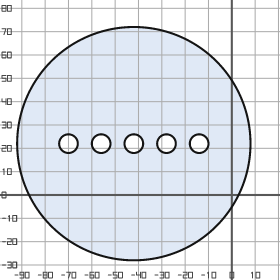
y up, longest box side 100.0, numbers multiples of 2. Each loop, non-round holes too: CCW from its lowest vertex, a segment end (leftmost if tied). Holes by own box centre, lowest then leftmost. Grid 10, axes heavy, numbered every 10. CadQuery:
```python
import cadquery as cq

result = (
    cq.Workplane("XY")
    .moveTo(-42.0, 22.0)
    .circle(50.0)
    .moveTo(-70.0, 22.0)
    .circle(4.0)
    .moveTo(-56.0, 22.0)
    .circle(4.0)
    .moveTo(-42.0, 22.0)
    .circle(4.0)
    .moveTo(-28.0, 22.0)
    .circle(4.0)
    .moveTo(-14.0, 22.0)
    .circle(4.0)
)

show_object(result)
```